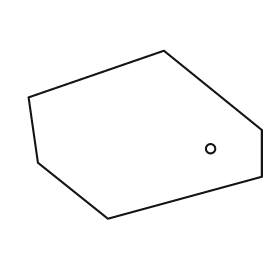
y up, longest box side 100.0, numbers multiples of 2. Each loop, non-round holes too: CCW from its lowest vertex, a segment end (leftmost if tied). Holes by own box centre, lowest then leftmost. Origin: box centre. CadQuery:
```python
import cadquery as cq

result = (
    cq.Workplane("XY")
    .moveTo(-16.0, -36.0)
    .lineTo(50.0, -18.0)
    .lineTo(50.0, 2.0)
    .lineTo(8.0, 36.0)
    .lineTo(-50.0, 16.0)
    .lineTo(-46.0, -12.0)
    .close()
    .moveTo(28.0, -6.0)
    .circle(2.0)
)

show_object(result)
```